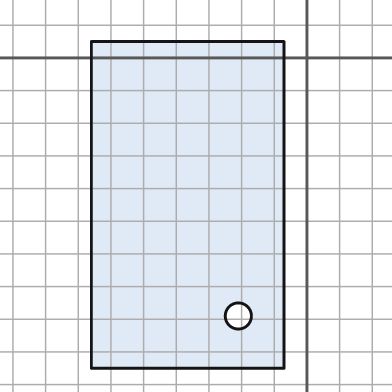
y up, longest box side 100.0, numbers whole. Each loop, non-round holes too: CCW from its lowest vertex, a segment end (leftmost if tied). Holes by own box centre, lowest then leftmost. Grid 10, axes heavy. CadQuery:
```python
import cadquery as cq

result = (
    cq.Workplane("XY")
    .moveTo(-66.0, -95.0)
    .lineTo(-7.0, -95.0)
    .lineTo(-7.0, 5.0)
    .lineTo(-66.0, 5.0)
    .close()
    .moveTo(-21.0, -79.0)
    .circle(4.0)
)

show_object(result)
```